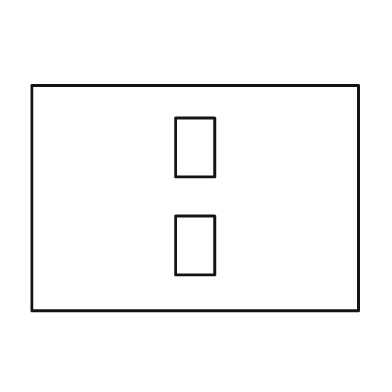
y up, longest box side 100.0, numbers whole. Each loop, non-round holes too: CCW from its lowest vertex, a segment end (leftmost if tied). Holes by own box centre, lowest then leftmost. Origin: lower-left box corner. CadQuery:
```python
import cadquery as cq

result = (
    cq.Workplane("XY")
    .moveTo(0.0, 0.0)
    .lineTo(100.0, 0.0)
    .lineTo(100.0, 69.0)
    .lineTo(0.0, 69.0)
    .close()
    .moveTo(44.0, 11.0)
    .lineTo(56.0, 11.0)
    .lineTo(56.0, 29.0)
    .lineTo(44.0, 29.0)
    .close()
    .moveTo(44.0, 41.0)
    .lineTo(56.0, 41.0)
    .lineTo(56.0, 59.0)
    .lineTo(44.0, 59.0)
    .close()
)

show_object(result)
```